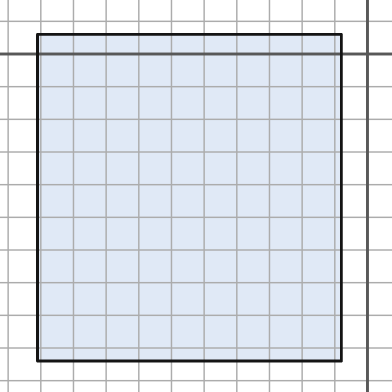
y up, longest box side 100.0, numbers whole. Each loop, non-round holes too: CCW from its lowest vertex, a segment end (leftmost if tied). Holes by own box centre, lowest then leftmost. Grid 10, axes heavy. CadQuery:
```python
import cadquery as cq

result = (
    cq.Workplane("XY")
    .moveTo(-101.0, -94.0)
    .lineTo(-8.0, -94.0)
    .lineTo(-8.0, 6.0)
    .lineTo(-101.0, 6.0)
    .close()
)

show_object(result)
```